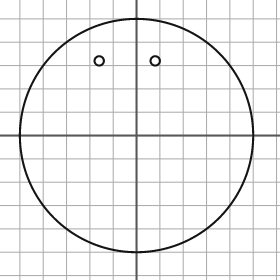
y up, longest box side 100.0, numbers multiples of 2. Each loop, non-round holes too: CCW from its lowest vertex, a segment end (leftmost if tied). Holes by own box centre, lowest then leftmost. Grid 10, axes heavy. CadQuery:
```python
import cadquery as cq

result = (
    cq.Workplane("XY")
    .moveTo(0.0, 0.0)
    .circle(50.0)
    .moveTo(-16.0, 32.0)
    .circle(2.0)
    .moveTo(8.0, 32.0)
    .circle(2.0)
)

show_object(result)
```